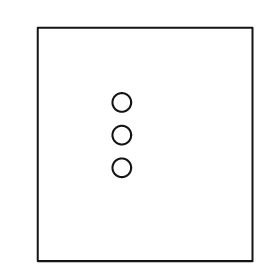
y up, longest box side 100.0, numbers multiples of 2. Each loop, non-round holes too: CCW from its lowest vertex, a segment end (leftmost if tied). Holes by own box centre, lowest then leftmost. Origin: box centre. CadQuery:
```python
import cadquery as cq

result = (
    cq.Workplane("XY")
    .moveTo(-46.0, -50.0)
    .lineTo(46.0, -50.0)
    .lineTo(46.0, 50.0)
    .lineTo(-46.0, 50.0)
    .close()
    .moveTo(-10.0, -10.0)
    .circle(4.0)
    .moveTo(-10.0, 4.0)
    .circle(4.0)
    .moveTo(-10.0, 18.0)
    .circle(4.0)
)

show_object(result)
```